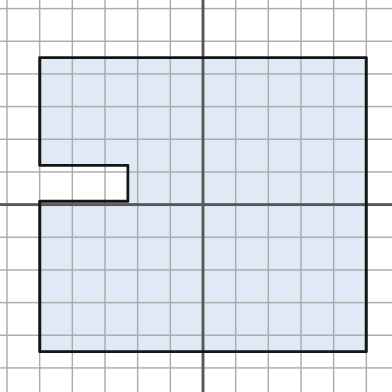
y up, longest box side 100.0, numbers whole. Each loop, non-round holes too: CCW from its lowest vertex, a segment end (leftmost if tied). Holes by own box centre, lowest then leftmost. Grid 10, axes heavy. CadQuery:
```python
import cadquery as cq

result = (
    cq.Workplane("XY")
    .moveTo(-50.0, -45.0)
    .lineTo(50.0, -45.0)
    .lineTo(50.0, 45.0)
    .lineTo(-50.0, 45.0)
    .lineTo(-50.0, 12.0)
    .lineTo(-23.0, 12.0)
    .lineTo(-23.0, 1.0)
    .lineTo(-50.0, 1.0)
    .close()
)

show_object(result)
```